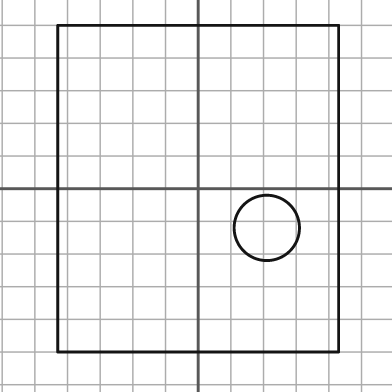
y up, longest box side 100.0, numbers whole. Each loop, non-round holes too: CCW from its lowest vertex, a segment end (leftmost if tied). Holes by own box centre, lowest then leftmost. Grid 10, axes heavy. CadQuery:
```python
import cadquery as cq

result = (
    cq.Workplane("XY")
    .moveTo(-43.0, -50.0)
    .lineTo(43.0, -50.0)
    .lineTo(43.0, 50.0)
    .lineTo(-43.0, 50.0)
    .close()
    .moveTo(21.0, -12.0)
    .circle(10.0)
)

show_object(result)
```